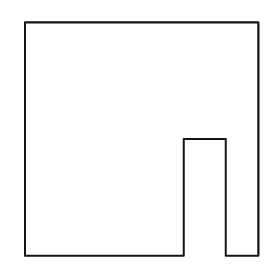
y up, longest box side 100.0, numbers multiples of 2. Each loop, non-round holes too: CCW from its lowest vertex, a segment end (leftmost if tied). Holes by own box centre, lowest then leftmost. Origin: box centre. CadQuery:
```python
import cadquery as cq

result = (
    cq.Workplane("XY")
    .moveTo(-50.0, -50.0)
    .lineTo(18.0, -50.0)
    .lineTo(18.0, 0.0)
    .lineTo(36.0, 0.0)
    .lineTo(36.0, -50.0)
    .lineTo(50.0, -50.0)
    .lineTo(50.0, 50.0)
    .lineTo(-50.0, 50.0)
    .close()
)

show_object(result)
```